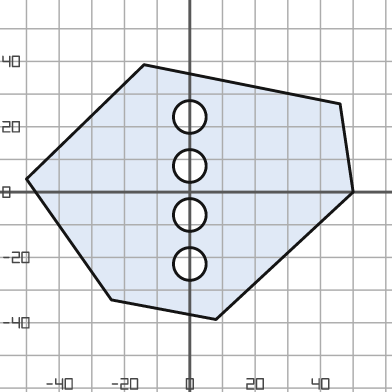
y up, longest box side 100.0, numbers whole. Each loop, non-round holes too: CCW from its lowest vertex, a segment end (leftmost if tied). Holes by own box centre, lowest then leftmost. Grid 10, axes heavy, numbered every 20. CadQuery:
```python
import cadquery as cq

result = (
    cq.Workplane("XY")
    .moveTo(8.0, -39.0)
    .lineTo(50.0, 0.0)
    .lineTo(46.0, 27.0)
    .lineTo(-14.0, 39.0)
    .lineTo(-50.0, 4.0)
    .lineTo(-24.0, -33.0)
    .close()
    .moveTo(0.0, -22.0)
    .circle(5.0)
    .moveTo(0.0, -7.0)
    .circle(5.0)
    .moveTo(0.0, 8.0)
    .circle(5.0)
    .moveTo(0.0, 23.0)
    .circle(5.0)
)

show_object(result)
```